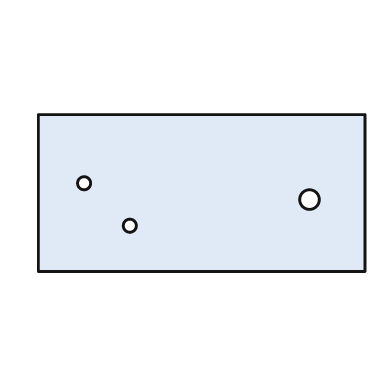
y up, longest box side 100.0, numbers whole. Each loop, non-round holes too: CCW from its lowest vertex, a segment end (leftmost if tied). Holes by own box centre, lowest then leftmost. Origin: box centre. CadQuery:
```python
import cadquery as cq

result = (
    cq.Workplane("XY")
    .moveTo(-50.0, -24.0)
    .lineTo(50.0, -24.0)
    .lineTo(50.0, 24.0)
    .lineTo(-50.0, 24.0)
    .close()
    .moveTo(-22.0, -10.0)
    .circle(2.0)
    .moveTo(33.0, -2.0)
    .circle(3.0)
    .moveTo(-36.0, 3.0)
    .circle(2.0)
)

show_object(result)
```